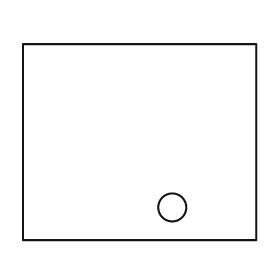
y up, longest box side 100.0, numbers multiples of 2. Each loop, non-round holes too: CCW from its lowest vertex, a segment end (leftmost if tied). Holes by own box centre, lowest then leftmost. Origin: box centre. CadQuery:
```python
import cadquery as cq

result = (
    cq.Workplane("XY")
    .moveTo(-50.0, -42.0)
    .lineTo(50.0, -42.0)
    .lineTo(50.0, 42.0)
    .lineTo(-50.0, 42.0)
    .close()
    .moveTo(14.0, -28.0)
    .circle(6.0)
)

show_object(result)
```